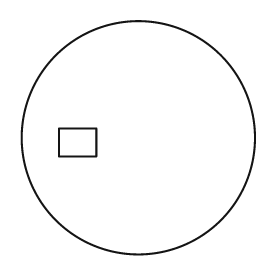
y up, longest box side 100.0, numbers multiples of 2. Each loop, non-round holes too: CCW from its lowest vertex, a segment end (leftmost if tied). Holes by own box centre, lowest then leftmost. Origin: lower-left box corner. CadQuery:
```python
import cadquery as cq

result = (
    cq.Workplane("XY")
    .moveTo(50.0, 50.0)
    .circle(50.0)
    .moveTo(16.0, 42.0)
    .lineTo(32.0, 42.0)
    .lineTo(32.0, 54.0)
    .lineTo(16.0, 54.0)
    .close()
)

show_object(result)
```